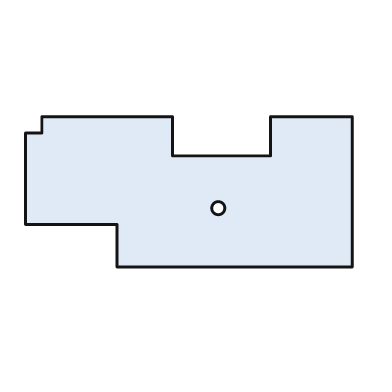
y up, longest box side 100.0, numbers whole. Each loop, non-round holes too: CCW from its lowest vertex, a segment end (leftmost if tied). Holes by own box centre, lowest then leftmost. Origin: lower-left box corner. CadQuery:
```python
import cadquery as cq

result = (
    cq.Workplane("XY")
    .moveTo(28.0, 0.0)
    .lineTo(100.0, 0.0)
    .lineTo(100.0, 46.0)
    .lineTo(75.0, 46.0)
    .lineTo(75.0, 34.0)
    .lineTo(45.0, 34.0)
    .lineTo(45.0, 46.0)
    .lineTo(5.0, 46.0)
    .lineTo(5.0, 41.0)
    .lineTo(0.0, 41.0)
    .lineTo(0.0, 13.0)
    .lineTo(28.0, 13.0)
    .close()
    .moveTo(59.0, 18.0)
    .circle(2.0)
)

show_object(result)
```